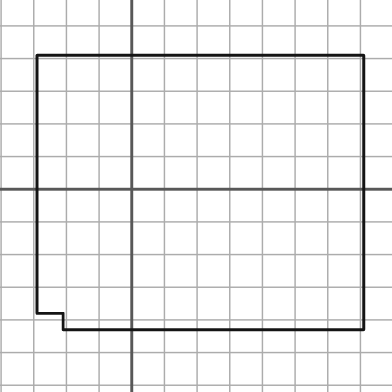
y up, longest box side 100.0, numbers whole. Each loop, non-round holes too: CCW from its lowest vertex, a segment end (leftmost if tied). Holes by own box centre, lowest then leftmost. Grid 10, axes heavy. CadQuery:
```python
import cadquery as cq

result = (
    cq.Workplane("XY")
    .moveTo(-21.0, -43.0)
    .lineTo(71.0, -43.0)
    .lineTo(71.0, 41.0)
    .lineTo(-29.0, 41.0)
    .lineTo(-29.0, -38.0)
    .lineTo(-21.0, -38.0)
    .close()
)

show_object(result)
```